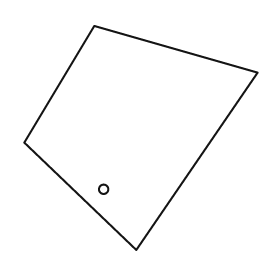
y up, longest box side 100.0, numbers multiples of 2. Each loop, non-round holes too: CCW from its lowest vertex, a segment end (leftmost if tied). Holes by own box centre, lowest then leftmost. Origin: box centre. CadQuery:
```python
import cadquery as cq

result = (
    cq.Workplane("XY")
    .moveTo(-2.0, -48.0)
    .lineTo(50.0, 28.0)
    .lineTo(-20.0, 48.0)
    .lineTo(-50.0, -2.0)
    .close()
    .moveTo(-16.0, -22.0)
    .circle(2.0)
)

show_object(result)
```